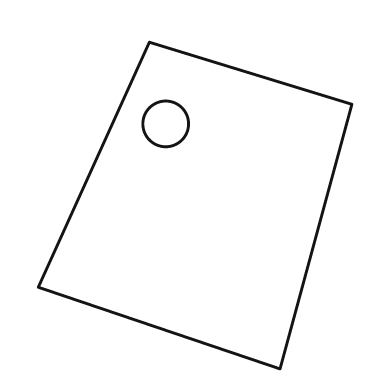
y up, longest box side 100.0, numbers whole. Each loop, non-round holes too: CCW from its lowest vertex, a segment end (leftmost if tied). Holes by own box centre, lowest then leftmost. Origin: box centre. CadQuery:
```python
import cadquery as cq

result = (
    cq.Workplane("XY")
    .moveTo(26.0, -50.0)
    .lineTo(48.0, 31.0)
    .lineTo(-14.0, 50.0)
    .lineTo(-48.0, -25.0)
    .close()
    .moveTo(-9.0, 25.0)
    .circle(7.0)
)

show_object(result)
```